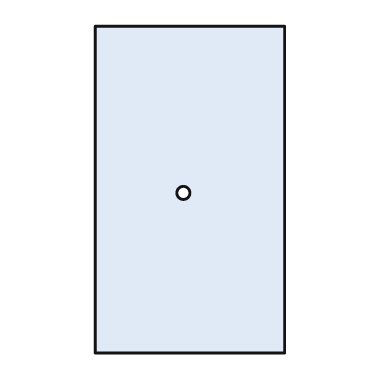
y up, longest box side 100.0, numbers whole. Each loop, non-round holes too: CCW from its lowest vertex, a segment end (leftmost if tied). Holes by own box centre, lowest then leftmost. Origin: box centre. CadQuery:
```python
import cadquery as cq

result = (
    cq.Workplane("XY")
    .moveTo(-29.0, -50.0)
    .lineTo(29.0, -50.0)
    .lineTo(29.0, 50.0)
    .lineTo(-29.0, 50.0)
    .close()
    .moveTo(-2.0, -1.0)
    .circle(2.0)
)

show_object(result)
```